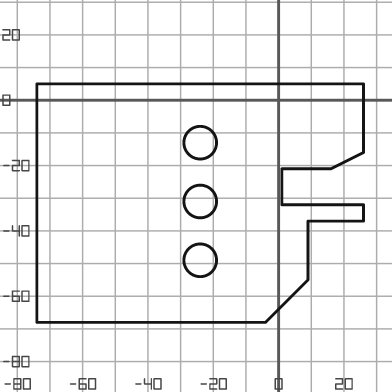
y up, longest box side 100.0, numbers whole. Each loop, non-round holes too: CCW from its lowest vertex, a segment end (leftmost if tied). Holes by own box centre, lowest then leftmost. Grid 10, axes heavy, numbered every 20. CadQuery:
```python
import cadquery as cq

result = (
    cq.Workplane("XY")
    .moveTo(-74.0, -68.0)
    .lineTo(-4.0, -68.0)
    .lineTo(9.0, -55.0)
    .lineTo(9.0, -37.0)
    .lineTo(26.0, -37.0)
    .lineTo(26.0, -32.0)
    .lineTo(1.0, -32.0)
    .lineTo(1.0, -21.0)
    .lineTo(16.0, -21.0)
    .lineTo(26.0, -16.0)
    .lineTo(26.0, 5.0)
    .lineTo(-74.0, 5.0)
    .close()
    .moveTo(-24.0, -49.0)
    .circle(5.0)
    .moveTo(-24.0, -31.0)
    .circle(5.0)
    .moveTo(-24.0, -13.0)
    .circle(5.0)
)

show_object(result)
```